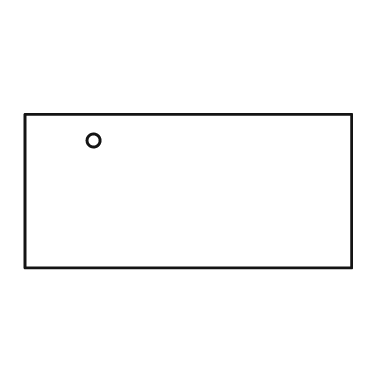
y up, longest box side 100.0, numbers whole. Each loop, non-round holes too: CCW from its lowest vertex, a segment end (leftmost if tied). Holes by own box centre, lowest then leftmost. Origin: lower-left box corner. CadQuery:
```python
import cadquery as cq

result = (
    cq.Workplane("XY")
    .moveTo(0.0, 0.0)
    .lineTo(100.0, 0.0)
    .lineTo(100.0, 47.0)
    .lineTo(0.0, 47.0)
    .close()
    .moveTo(21.0, 39.0)
    .circle(2.0)
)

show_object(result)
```